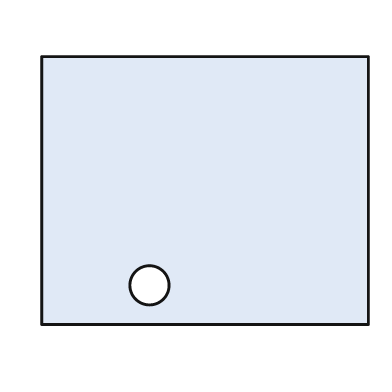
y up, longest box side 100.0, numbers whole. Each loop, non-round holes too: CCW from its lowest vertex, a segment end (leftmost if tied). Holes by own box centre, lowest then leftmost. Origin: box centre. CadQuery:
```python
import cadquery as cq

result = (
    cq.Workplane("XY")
    .moveTo(-50.0, -41.0)
    .lineTo(50.0, -41.0)
    .lineTo(50.0, 41.0)
    .lineTo(-50.0, 41.0)
    .close()
    .moveTo(-17.0, -29.0)
    .circle(6.0)
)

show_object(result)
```